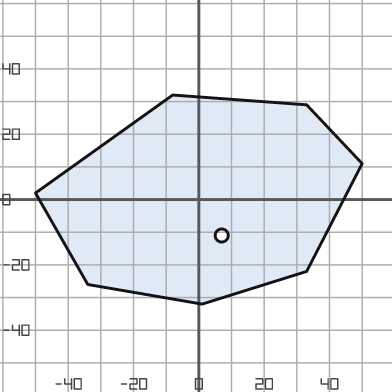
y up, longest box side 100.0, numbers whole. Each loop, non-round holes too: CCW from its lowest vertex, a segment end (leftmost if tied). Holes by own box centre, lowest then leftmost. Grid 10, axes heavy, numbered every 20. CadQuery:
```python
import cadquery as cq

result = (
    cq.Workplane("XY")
    .moveTo(1.0, -32.0)
    .lineTo(33.0, -22.0)
    .lineTo(50.0, 11.0)
    .lineTo(33.0, 29.0)
    .lineTo(-8.0, 32.0)
    .lineTo(-50.0, 2.0)
    .lineTo(-34.0, -26.0)
    .close()
    .moveTo(7.0, -11.0)
    .circle(2.0)
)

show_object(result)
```